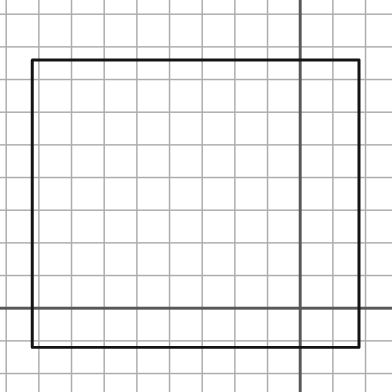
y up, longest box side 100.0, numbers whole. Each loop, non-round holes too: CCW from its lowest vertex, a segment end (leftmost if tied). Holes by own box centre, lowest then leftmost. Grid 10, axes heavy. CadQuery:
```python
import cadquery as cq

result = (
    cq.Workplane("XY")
    .moveTo(-82.0, -12.0)
    .lineTo(18.0, -12.0)
    .lineTo(18.0, 76.0)
    .lineTo(-82.0, 76.0)
    .close()
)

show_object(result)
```